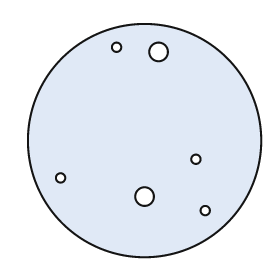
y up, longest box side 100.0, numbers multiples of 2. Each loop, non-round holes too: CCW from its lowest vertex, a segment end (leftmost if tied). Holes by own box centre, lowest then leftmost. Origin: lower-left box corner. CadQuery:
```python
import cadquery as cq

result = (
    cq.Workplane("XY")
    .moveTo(50.0, 50.0)
    .circle(50.0)
    .moveTo(76.0, 20.0)
    .circle(2.0)
    .moveTo(50.0, 26.0)
    .circle(4.0)
    .moveTo(14.0, 34.0)
    .circle(2.0)
    .moveTo(72.0, 42.0)
    .circle(2.0)
    .moveTo(56.0, 88.0)
    .circle(4.0)
    .moveTo(38.0, 90.0)
    .circle(2.0)
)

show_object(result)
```